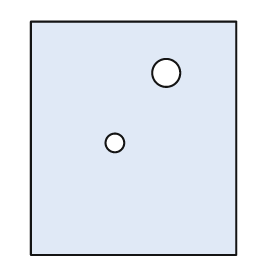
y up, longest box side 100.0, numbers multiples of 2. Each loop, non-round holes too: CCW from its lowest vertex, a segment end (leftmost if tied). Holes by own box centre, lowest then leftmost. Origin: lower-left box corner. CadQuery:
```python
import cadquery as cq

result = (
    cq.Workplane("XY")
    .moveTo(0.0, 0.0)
    .lineTo(88.0, 0.0)
    .lineTo(88.0, 100.0)
    .lineTo(0.0, 100.0)
    .close()
    .moveTo(36.0, 48.0)
    .circle(4.0)
    .moveTo(58.0, 78.0)
    .circle(6.0)
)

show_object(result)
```